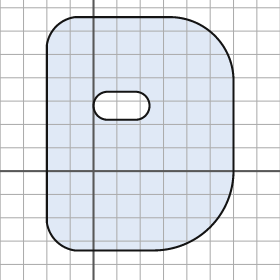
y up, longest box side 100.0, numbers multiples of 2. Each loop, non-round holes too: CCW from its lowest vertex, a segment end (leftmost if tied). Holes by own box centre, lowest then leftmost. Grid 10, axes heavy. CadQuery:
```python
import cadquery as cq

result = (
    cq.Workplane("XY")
    .moveTo(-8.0, -34.0)
    .lineTo(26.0, -34.0)
    .threePointArc((50.0, -24.0), (60.0, 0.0))
    .lineTo(60.0, 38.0)
    .threePointArc((52.0, 58.0), (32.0, 66.0))
    .lineTo(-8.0, 66.0)
    .threePointArc((-16.0, 62.0), (-20.0, 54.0))
    .lineTo(-20.0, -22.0)
    .threePointArc((-16.0, -30.0), (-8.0, -34.0))
    .close()
    .moveTo(6.0, 22.0)
    .lineTo(18.0, 22.0)
    .threePointArc((24.0, 28.0), (18.0, 34.0))
    .lineTo(6.0, 34.0)
    .threePointArc((0.0, 28.0), (6.0, 22.0))
    .close()
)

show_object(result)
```